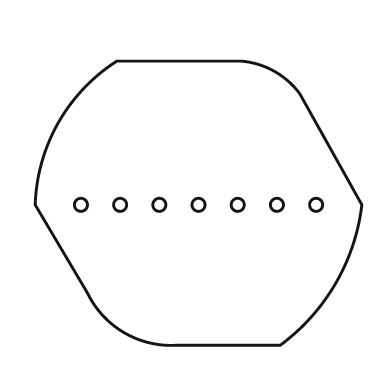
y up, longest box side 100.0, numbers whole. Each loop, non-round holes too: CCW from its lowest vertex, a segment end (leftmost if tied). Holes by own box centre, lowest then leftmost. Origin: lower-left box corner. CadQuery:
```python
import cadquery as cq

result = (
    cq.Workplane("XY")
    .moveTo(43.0, 0.0)
    .lineTo(75.0, 0.0)
    .threePointArc((92.0, 19.0), (100.0, 43.0))
    .lineTo(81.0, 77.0)
    .threePointArc((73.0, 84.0), (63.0, 87.0))
    .lineTo(25.0, 87.0)
    .threePointArc((7.0, 68.0), (0.0, 43.0))
    .lineTo(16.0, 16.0)
    .threePointArc((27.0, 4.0), (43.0, 0.0))
    .close()
    .moveTo(14.0, 43.0)
    .circle(2.0)
    .moveTo(26.0, 43.0)
    .circle(2.0)
    .moveTo(38.0, 43.0)
    .circle(2.0)
    .moveTo(50.0, 43.0)
    .circle(2.0)
    .moveTo(62.0, 43.0)
    .circle(2.0)
    .moveTo(74.0, 43.0)
    .circle(2.0)
    .moveTo(86.0, 43.0)
    .circle(2.0)
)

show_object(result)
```